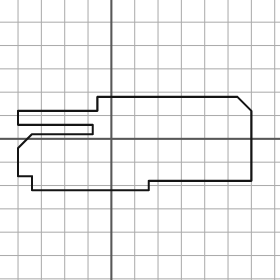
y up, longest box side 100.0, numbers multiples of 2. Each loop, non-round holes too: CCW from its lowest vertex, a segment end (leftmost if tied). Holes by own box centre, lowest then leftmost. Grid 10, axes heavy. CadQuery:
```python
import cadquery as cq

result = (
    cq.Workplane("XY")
    .moveTo(-34.0, -22.0)
    .lineTo(16.0, -22.0)
    .lineTo(16.0, -18.0)
    .lineTo(60.0, -18.0)
    .lineTo(60.0, 12.0)
    .lineTo(54.0, 18.0)
    .lineTo(-6.0, 18.0)
    .lineTo(-6.0, 12.0)
    .lineTo(-40.0, 12.0)
    .lineTo(-40.0, 6.0)
    .lineTo(-8.0, 6.0)
    .lineTo(-8.0, 2.0)
    .lineTo(-34.0, 2.0)
    .lineTo(-40.0, -4.0)
    .lineTo(-40.0, -16.0)
    .lineTo(-34.0, -16.0)
    .close()
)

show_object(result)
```